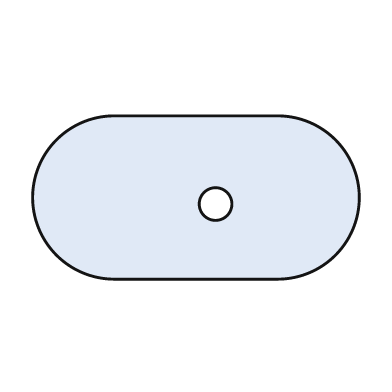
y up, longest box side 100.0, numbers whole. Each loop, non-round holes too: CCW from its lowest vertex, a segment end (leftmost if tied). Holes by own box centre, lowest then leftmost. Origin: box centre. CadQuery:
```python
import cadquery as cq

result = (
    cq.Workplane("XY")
    .moveTo(-25.0, -25.0)
    .lineTo(25.0, -25.0)
    .threePointArc((50.0, 0.0), (25.0, 25.0))
    .lineTo(-25.0, 25.0)
    .threePointArc((-50.0, 0.0), (-25.0, -25.0))
    .close()
    .moveTo(6.0, -2.0)
    .circle(5.0)
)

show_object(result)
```